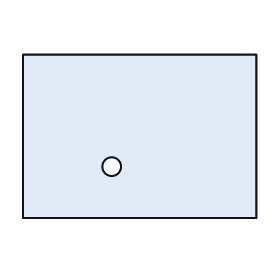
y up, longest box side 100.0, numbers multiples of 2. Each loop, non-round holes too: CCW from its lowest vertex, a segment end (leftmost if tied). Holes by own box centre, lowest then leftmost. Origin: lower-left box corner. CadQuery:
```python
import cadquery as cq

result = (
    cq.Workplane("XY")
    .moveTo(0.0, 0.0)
    .lineTo(100.0, 0.0)
    .lineTo(100.0, 70.0)
    .lineTo(0.0, 70.0)
    .close()
    .moveTo(38.0, 22.0)
    .circle(4.0)
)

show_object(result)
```